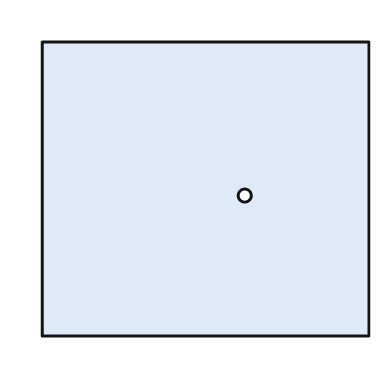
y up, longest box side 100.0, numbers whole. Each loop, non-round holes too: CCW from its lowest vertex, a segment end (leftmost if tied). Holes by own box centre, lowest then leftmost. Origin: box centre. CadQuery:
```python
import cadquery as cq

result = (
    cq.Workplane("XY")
    .moveTo(-50.0, -45.0)
    .lineTo(50.0, -45.0)
    .lineTo(50.0, 45.0)
    .lineTo(-50.0, 45.0)
    .close()
    .moveTo(12.0, -2.0)
    .circle(2.0)
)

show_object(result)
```